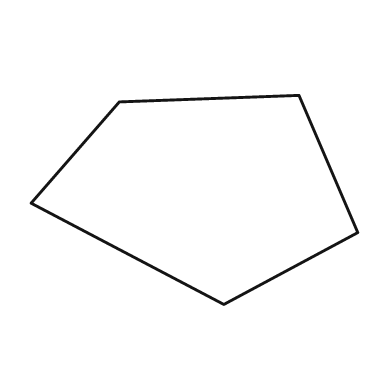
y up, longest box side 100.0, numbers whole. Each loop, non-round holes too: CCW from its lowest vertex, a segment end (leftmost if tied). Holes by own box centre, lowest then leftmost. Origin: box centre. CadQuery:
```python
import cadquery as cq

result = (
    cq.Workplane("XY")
    .moveTo(9.0, -32.0)
    .lineTo(50.0, -10.0)
    .lineTo(32.0, 32.0)
    .lineTo(-23.0, 30.0)
    .lineTo(-50.0, -1.0)
    .close()
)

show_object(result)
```